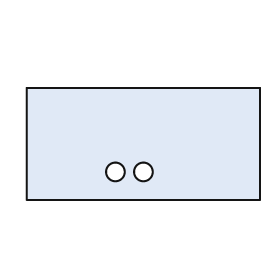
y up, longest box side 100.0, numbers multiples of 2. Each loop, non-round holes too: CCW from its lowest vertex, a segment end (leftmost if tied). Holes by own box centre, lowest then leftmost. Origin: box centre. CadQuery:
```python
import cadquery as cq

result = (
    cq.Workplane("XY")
    .moveTo(-50.0, -24.0)
    .lineTo(50.0, -24.0)
    .lineTo(50.0, 24.0)
    .lineTo(-50.0, 24.0)
    .close()
    .moveTo(-12.0, -12.0)
    .circle(4.0)
    .moveTo(0.0, -12.0)
    .circle(4.0)
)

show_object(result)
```